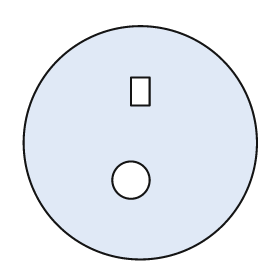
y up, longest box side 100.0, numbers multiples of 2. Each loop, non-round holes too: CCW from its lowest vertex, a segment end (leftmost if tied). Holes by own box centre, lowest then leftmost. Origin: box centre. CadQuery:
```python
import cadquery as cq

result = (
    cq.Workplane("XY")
    .moveTo(0.0, 0.0)
    .circle(50.0)
    .moveTo(-4.0, -16.0)
    .circle(8.0)
    .moveTo(-4.0, 16.0)
    .lineTo(4.0, 16.0)
    .lineTo(4.0, 28.0)
    .lineTo(-4.0, 28.0)
    .close()
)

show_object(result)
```